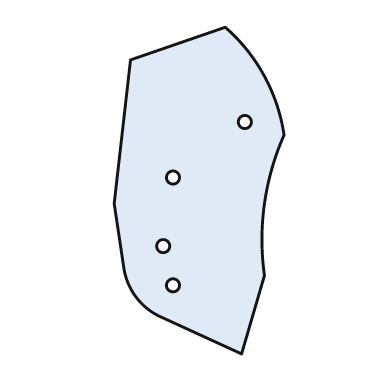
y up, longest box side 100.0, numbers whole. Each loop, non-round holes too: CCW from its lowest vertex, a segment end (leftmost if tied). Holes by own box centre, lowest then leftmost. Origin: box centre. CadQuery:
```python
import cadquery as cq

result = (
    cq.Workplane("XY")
    .moveTo(13.0, -50.0)
    .lineTo(20.0, -26.0)
    .threePointArc((20.0, -4.0), (26.0, 17.0))
    .threePointArc((20.0, 35.0), (8.0, 50.0))
    .lineTo(-21.0, 40.0)
    .lineTo(-26.0, -4.0)
    .lineTo(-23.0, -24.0)
    .threePointArc((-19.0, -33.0), (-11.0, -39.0))
    .close()
    .moveTo(-8.0, -29.0)
    .circle(2.0)
    .moveTo(-11.0, -17.0)
    .circle(2.0)
    .moveTo(-8.0, 4.0)
    .circle(2.0)
    .moveTo(14.0, 21.0)
    .circle(2.0)
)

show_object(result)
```